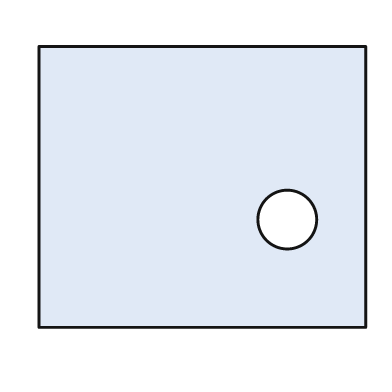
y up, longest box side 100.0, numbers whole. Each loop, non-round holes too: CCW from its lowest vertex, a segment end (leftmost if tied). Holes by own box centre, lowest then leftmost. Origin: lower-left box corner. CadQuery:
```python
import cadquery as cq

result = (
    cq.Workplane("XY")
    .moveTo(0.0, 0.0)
    .lineTo(100.0, 0.0)
    .lineTo(100.0, 86.0)
    .lineTo(0.0, 86.0)
    .close()
    .moveTo(76.0, 33.0)
    .circle(9.0)
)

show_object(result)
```